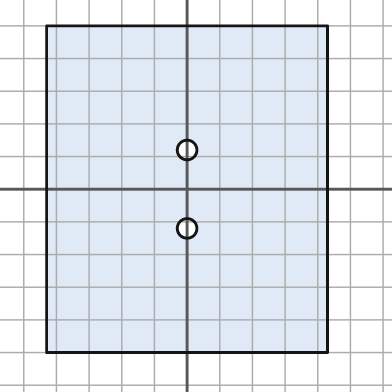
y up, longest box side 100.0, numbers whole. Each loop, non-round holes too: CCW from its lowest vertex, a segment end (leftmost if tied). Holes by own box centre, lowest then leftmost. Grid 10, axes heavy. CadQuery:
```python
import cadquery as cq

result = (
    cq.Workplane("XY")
    .moveTo(-43.0, -50.0)
    .lineTo(43.0, -50.0)
    .lineTo(43.0, 50.0)
    .lineTo(-43.0, 50.0)
    .close()
    .moveTo(0.0, -12.0)
    .circle(3.0)
    .moveTo(0.0, 12.0)
    .circle(3.0)
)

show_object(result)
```